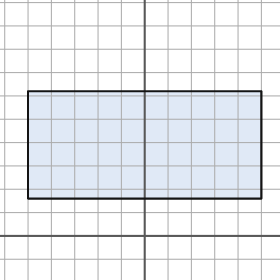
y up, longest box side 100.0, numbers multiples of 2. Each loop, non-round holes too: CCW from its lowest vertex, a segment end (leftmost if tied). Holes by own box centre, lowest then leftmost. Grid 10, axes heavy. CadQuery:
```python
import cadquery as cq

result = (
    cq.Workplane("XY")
    .moveTo(-50.0, 16.0)
    .lineTo(50.0, 16.0)
    .lineTo(50.0, 62.0)
    .lineTo(-50.0, 62.0)
    .close()
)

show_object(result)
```